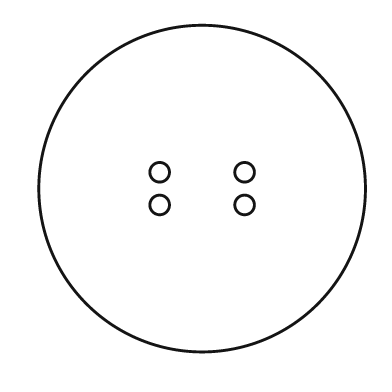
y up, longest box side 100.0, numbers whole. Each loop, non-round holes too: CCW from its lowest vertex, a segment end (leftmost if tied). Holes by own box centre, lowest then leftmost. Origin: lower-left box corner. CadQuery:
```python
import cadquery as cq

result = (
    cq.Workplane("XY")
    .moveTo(50.0, 50.0)
    .circle(50.0)
    .moveTo(37.0, 45.0)
    .circle(3.0)
    .moveTo(63.0, 45.0)
    .circle(3.0)
    .moveTo(37.0, 55.0)
    .circle(3.0)
    .moveTo(63.0, 55.0)
    .circle(3.0)
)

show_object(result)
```